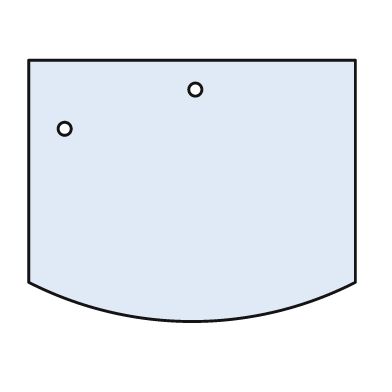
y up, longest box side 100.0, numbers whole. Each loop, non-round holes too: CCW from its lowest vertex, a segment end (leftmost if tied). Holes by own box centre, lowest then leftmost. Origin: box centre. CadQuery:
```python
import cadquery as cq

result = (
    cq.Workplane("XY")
    .moveTo(-50.0, -28.0)
    .threePointArc((0.0, -40.0), (50.0, -28.0))
    .lineTo(50.0, 40.0)
    .lineTo(-50.0, 40.0)
    .close()
    .moveTo(-39.0, 19.0)
    .circle(2.0)
    .moveTo(1.0, 31.0)
    .circle(2.0)
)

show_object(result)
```